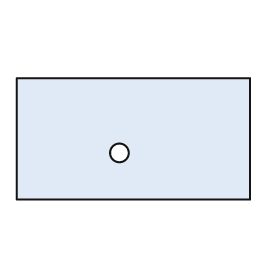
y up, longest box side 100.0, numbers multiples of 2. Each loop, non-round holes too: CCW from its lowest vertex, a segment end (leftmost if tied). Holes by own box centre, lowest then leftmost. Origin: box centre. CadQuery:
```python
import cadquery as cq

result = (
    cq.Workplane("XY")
    .moveTo(-50.0, -26.0)
    .lineTo(50.0, -26.0)
    .lineTo(50.0, 26.0)
    .lineTo(-50.0, 26.0)
    .close()
    .moveTo(-6.0, -6.0)
    .circle(4.0)
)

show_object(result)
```